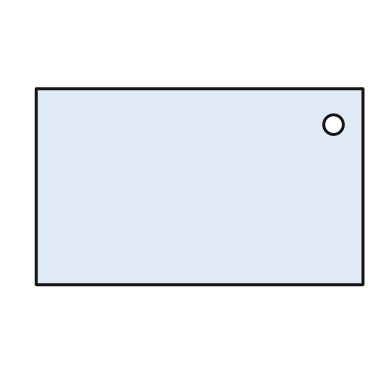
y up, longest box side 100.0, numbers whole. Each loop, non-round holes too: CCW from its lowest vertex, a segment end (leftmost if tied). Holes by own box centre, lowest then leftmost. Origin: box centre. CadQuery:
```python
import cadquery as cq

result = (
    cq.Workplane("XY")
    .moveTo(-50.0, -30.0)
    .lineTo(50.0, -30.0)
    .lineTo(50.0, 30.0)
    .lineTo(-50.0, 30.0)
    .close()
    .moveTo(41.0, 19.0)
    .circle(3.0)
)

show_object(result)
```